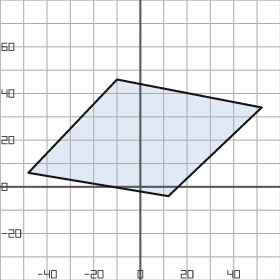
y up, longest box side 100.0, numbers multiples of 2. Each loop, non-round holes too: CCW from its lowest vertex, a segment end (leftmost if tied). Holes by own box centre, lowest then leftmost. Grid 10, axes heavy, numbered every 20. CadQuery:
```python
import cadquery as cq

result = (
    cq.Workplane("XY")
    .moveTo(12.0, -4.0)
    .lineTo(52.0, 34.0)
    .lineTo(-10.0, 46.0)
    .lineTo(-48.0, 6.0)
    .close()
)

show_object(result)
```